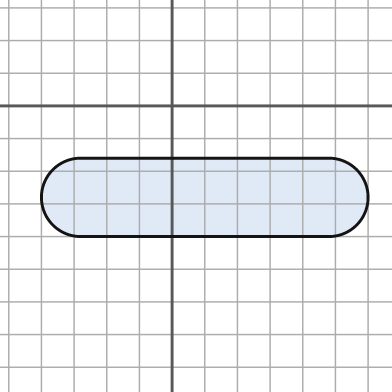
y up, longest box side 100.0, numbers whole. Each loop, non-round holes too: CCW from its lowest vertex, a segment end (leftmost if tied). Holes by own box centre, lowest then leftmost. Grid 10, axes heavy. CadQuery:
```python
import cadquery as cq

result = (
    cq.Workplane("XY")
    .moveTo(-28.0, -40.0)
    .lineTo(48.0, -40.0)
    .threePointArc((60.0, -28.0), (48.0, -16.0))
    .lineTo(-28.0, -16.0)
    .threePointArc((-40.0, -28.0), (-28.0, -40.0))
    .close()
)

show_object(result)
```